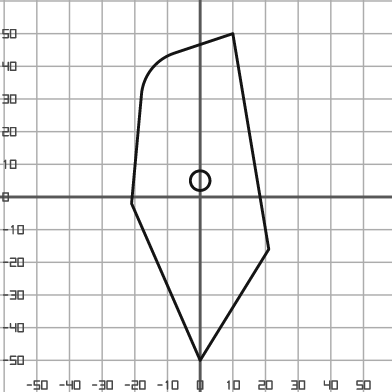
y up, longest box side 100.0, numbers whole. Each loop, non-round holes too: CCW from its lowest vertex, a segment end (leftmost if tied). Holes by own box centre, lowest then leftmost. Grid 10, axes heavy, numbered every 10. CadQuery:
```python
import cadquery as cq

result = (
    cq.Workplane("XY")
    .moveTo(0.0, -50.0)
    .lineTo(21.0, -16.0)
    .lineTo(10.0, 50.0)
    .lineTo(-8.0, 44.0)
    .threePointArc((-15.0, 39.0), (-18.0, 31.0))
    .lineTo(-21.0, -2.0)
    .close()
    .moveTo(0.0, 5.0)
    .circle(3.0)
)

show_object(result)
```